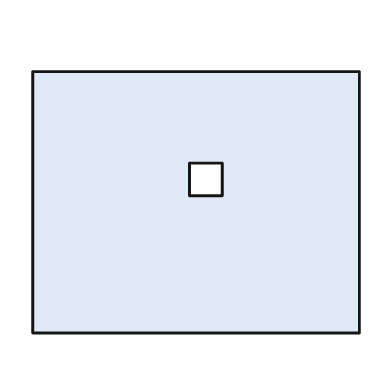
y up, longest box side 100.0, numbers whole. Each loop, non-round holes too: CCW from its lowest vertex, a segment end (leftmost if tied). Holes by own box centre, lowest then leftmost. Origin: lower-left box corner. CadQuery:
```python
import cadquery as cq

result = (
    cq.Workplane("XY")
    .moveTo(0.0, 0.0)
    .lineTo(100.0, 0.0)
    .lineTo(100.0, 80.0)
    .lineTo(0.0, 80.0)
    .close()
    .moveTo(48.0, 42.0)
    .lineTo(58.0, 42.0)
    .lineTo(58.0, 52.0)
    .lineTo(48.0, 52.0)
    .close()
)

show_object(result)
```